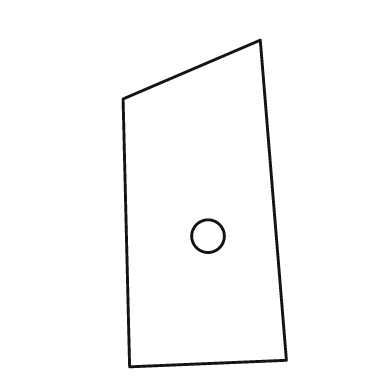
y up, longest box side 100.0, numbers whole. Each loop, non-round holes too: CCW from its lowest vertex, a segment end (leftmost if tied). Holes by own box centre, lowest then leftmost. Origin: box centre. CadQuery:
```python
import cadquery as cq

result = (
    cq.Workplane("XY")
    .moveTo(-23.0, -50.0)
    .lineTo(25.0, -48.0)
    .lineTo(17.0, 50.0)
    .lineTo(-25.0, 32.0)
    .close()
    .moveTo(1.0, -10.0)
    .circle(5.0)
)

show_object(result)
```